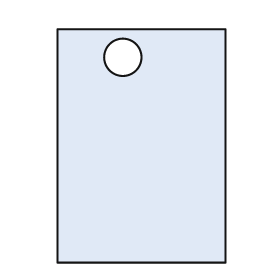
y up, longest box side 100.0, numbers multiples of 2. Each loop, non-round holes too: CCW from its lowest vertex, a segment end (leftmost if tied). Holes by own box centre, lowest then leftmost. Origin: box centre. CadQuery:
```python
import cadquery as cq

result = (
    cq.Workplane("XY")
    .moveTo(-36.0, -50.0)
    .lineTo(36.0, -50.0)
    .lineTo(36.0, 50.0)
    .lineTo(-36.0, 50.0)
    .close()
    .moveTo(-8.0, 38.0)
    .circle(8.0)
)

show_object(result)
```